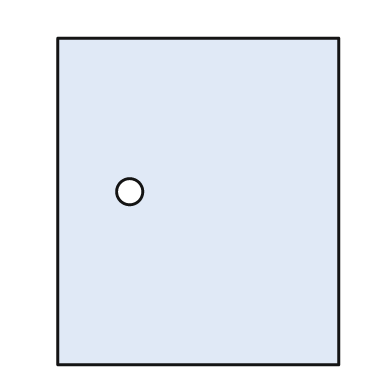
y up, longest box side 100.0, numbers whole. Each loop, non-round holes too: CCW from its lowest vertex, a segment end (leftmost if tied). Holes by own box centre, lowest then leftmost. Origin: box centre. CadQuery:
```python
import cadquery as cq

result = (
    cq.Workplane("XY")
    .moveTo(-43.0, -50.0)
    .lineTo(43.0, -50.0)
    .lineTo(43.0, 50.0)
    .lineTo(-43.0, 50.0)
    .close()
    .moveTo(-21.0, 3.0)
    .circle(4.0)
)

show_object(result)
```